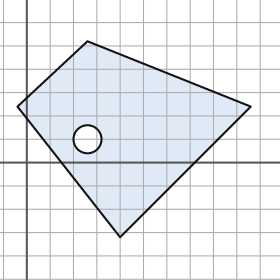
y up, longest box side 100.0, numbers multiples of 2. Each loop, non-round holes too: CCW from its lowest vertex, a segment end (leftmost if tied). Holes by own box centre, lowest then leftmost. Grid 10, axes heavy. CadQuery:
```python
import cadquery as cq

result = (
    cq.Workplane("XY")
    .moveTo(40.0, -32.0)
    .lineTo(96.0, 24.0)
    .lineTo(26.0, 52.0)
    .lineTo(-4.0, 24.0)
    .close()
    .moveTo(26.0, 10.0)
    .circle(6.0)
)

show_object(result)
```